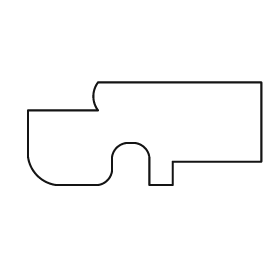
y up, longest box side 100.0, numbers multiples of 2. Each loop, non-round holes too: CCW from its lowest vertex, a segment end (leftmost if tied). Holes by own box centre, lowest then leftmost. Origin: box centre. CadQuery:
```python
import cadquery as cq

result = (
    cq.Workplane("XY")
    .moveTo(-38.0, -22.0)
    .lineTo(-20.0, -22.0)
    .threePointArc((-16.0, -20.0), (-14.0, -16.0))
    .lineTo(-14.0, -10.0)
    .threePointArc((-12.0, -6.0), (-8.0, -4.0))
    .lineTo(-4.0, -4.0)
    .threePointArc((0.0, -6.0), (2.0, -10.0))
    .lineTo(2.0, -22.0)
    .lineTo(12.0, -22.0)
    .lineTo(12.0, -12.0)
    .lineTo(50.0, -12.0)
    .lineTo(50.0, 22.0)
    .lineTo(-20.0, 22.0)
    .threePointArc((-22.0, 16.0), (-20.0, 10.0))
    .lineTo(-50.0, 10.0)
    .lineTo(-50.0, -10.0)
    .threePointArc((-46.0, -18.0), (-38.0, -22.0))
    .close()
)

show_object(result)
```